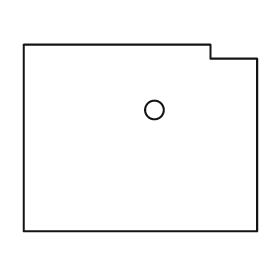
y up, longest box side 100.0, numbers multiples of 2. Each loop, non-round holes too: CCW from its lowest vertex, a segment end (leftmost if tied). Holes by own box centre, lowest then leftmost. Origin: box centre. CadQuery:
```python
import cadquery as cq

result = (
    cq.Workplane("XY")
    .moveTo(-50.0, -40.0)
    .lineTo(50.0, -40.0)
    .lineTo(50.0, 34.0)
    .lineTo(30.0, 34.0)
    .lineTo(30.0, 40.0)
    .lineTo(-50.0, 40.0)
    .close()
    .moveTo(6.0, 12.0)
    .circle(4.0)
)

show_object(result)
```